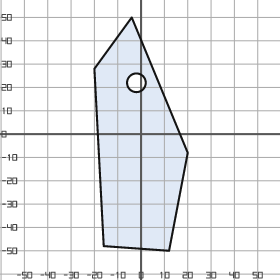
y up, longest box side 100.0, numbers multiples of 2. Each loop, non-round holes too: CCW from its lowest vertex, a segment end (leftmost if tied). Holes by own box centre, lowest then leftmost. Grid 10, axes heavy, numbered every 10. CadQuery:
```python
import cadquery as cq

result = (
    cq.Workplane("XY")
    .moveTo(12.0, -50.0)
    .lineTo(20.0, -8.0)
    .lineTo(-4.0, 50.0)
    .lineTo(-20.0, 28.0)
    .lineTo(-16.0, -48.0)
    .close()
    .moveTo(-2.0, 22.0)
    .circle(4.0)
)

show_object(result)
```